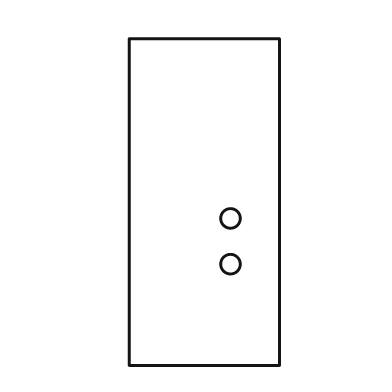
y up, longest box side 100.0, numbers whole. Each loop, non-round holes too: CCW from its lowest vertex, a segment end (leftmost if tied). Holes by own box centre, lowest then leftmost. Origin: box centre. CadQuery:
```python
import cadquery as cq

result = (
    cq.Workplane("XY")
    .moveTo(-23.0, -50.0)
    .lineTo(23.0, -50.0)
    .lineTo(23.0, 50.0)
    .lineTo(-23.0, 50.0)
    .close()
    .moveTo(8.0, -19.0)
    .circle(3.0)
    .moveTo(8.0, -5.0)
    .circle(3.0)
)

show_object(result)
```